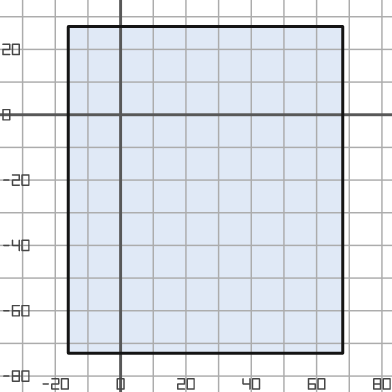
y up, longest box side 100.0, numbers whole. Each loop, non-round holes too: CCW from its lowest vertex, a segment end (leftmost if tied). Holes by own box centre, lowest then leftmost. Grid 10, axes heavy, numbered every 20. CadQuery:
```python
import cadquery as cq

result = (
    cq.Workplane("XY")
    .moveTo(-16.0, -73.0)
    .lineTo(68.0, -73.0)
    .lineTo(68.0, 27.0)
    .lineTo(-16.0, 27.0)
    .close()
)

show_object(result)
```